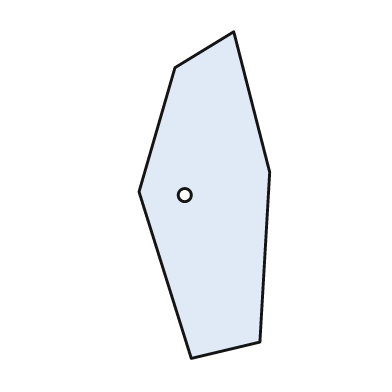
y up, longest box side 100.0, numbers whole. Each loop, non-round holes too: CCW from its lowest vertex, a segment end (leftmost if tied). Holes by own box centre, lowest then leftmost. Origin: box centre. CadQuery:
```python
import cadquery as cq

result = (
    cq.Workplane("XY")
    .moveTo(-4.0, -50.0)
    .lineTo(17.0, -45.0)
    .lineTo(20.0, 7.0)
    .lineTo(9.0, 50.0)
    .lineTo(-9.0, 39.0)
    .lineTo(-20.0, 1.0)
    .close()
    .moveTo(-6.0, 0.0)
    .circle(2.0)
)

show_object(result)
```